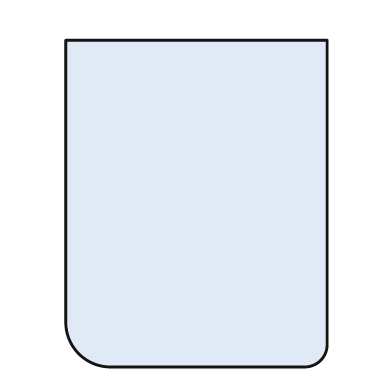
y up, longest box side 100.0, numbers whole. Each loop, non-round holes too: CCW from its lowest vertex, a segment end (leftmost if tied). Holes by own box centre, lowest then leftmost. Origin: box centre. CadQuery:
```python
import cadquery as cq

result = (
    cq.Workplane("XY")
    .moveTo(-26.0, -50.0)
    .lineTo(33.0, -50.0)
    .threePointArc((38.0, -48.0), (40.0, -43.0))
    .lineTo(40.0, 50.0)
    .lineTo(-40.0, 50.0)
    .lineTo(-40.0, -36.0)
    .threePointArc((-36.0, -46.0), (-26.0, -50.0))
    .close()
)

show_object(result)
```